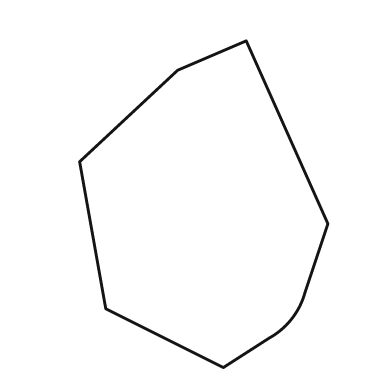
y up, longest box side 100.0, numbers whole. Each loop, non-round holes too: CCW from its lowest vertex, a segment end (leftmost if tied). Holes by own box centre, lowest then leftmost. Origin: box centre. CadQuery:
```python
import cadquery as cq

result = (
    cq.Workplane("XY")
    .moveTo(6.0, -50.0)
    .lineTo(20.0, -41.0)
    .threePointArc((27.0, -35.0), (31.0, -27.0))
    .lineTo(38.0, -6.0)
    .lineTo(13.0, 50.0)
    .lineTo(-8.0, 41.0)
    .lineTo(-38.0, 13.0)
    .lineTo(-30.0, -32.0)
    .close()
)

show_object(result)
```